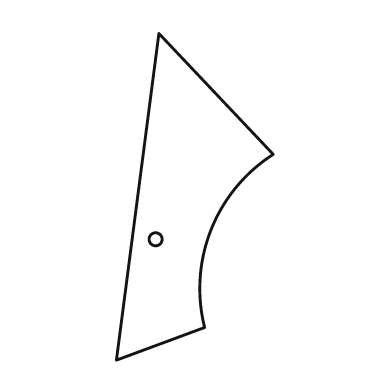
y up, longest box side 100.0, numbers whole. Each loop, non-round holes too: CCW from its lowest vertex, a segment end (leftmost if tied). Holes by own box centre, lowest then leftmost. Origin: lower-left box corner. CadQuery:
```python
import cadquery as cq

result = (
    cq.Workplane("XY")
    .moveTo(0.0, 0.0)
    .lineTo(27.0, 10.0)
    .threePointArc((29.0, 40.0), (48.0, 63.0))
    .lineTo(13.0, 100.0)
    .close()
    .moveTo(12.0, 37.0)
    .circle(2.0)
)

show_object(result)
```